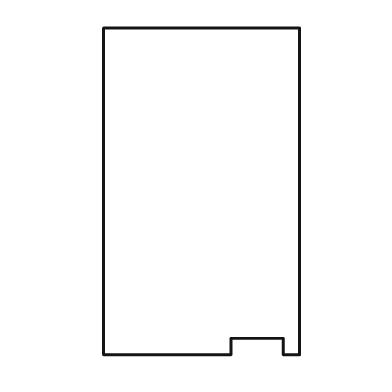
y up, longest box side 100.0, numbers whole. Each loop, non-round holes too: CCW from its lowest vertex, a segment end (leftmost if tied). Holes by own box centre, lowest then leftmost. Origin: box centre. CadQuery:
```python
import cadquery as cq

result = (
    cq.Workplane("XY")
    .moveTo(-30.0, -50.0)
    .lineTo(9.0, -50.0)
    .lineTo(9.0, -45.0)
    .lineTo(25.0, -45.0)
    .lineTo(25.0, -50.0)
    .lineTo(30.0, -50.0)
    .lineTo(30.0, 50.0)
    .lineTo(-30.0, 50.0)
    .close()
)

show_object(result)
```